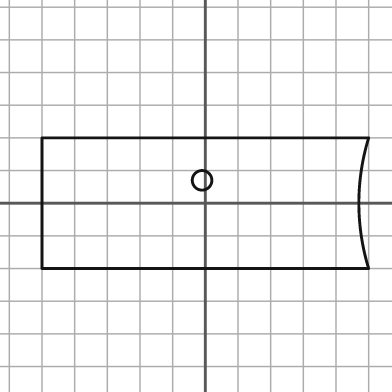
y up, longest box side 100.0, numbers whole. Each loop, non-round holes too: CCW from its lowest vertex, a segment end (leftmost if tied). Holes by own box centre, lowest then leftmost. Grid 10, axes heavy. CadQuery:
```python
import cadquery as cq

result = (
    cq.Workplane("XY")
    .moveTo(-50.0, -20.0)
    .lineTo(50.0, -20.0)
    .threePointArc((47.0, 0.0), (50.0, 20.0))
    .lineTo(-50.0, 20.0)
    .close()
    .moveTo(-1.0, 7.0)
    .circle(3.0)
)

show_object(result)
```